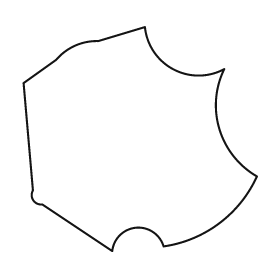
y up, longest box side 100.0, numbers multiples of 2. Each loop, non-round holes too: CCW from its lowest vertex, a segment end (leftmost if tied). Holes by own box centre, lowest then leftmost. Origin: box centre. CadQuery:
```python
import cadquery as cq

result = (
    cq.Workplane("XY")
    .moveTo(-12.0, -48.0)
    .threePointArc((-2.0, -38.0), (10.0, -46.0))
    .threePointArc((34.0, -36.0), (50.0, -16.0))
    .threePointArc((34.0, 4.0), (36.0, 30.0))
    .threePointArc((14.0, 30.0), (2.0, 48.0))
    .lineTo(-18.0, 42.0)
    .threePointArc((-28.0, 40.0), (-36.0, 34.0))
    .lineTo(-50.0, 24.0)
    .lineTo(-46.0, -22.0)
    .threePointArc((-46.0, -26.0), (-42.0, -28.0))
    .close()
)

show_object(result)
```